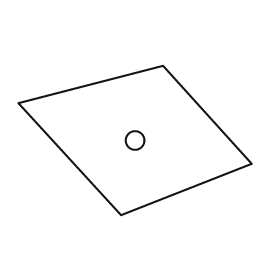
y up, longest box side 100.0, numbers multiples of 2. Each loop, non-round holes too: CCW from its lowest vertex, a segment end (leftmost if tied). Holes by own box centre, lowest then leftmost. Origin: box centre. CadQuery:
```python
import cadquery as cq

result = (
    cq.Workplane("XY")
    .moveTo(-6.0, -32.0)
    .lineTo(50.0, -10.0)
    .lineTo(12.0, 32.0)
    .lineTo(-50.0, 16.0)
    .close()
    .moveTo(0.0, 0.0)
    .circle(4.0)
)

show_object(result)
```